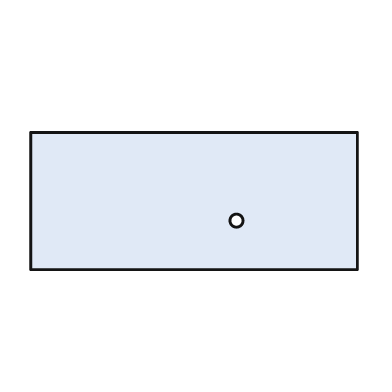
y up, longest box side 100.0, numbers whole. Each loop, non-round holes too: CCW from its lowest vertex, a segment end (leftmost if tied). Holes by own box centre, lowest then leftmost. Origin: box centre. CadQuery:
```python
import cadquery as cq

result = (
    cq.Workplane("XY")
    .moveTo(-50.0, -21.0)
    .lineTo(50.0, -21.0)
    .lineTo(50.0, 21.0)
    .lineTo(-50.0, 21.0)
    .close()
    .moveTo(13.0, -6.0)
    .circle(2.0)
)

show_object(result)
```